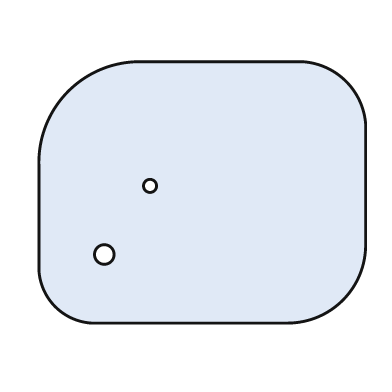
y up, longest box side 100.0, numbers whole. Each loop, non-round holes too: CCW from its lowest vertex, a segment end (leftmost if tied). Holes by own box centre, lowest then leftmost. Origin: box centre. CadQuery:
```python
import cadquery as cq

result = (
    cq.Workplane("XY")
    .moveTo(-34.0, -40.0)
    .lineTo(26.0, -40.0)
    .threePointArc((43.0, -33.0), (50.0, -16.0))
    .lineTo(50.0, 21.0)
    .threePointArc((44.0, 34.0), (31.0, 40.0))
    .lineTo(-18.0, 40.0)
    .threePointArc((-41.0, 31.0), (-50.0, 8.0))
    .lineTo(-50.0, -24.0)
    .threePointArc((-45.0, -35.0), (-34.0, -40.0))
    .close()
    .moveTo(-30.0, -19.0)
    .circle(3.0)
    .moveTo(-16.0, 2.0)
    .circle(2.0)
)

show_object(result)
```